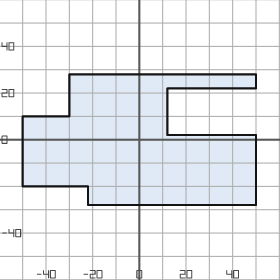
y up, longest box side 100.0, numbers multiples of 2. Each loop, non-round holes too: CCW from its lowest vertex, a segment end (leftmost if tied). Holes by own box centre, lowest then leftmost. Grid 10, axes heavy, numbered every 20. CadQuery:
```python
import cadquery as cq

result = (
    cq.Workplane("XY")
    .moveTo(-22.0, -28.0)
    .lineTo(50.0, -28.0)
    .lineTo(50.0, 2.0)
    .lineTo(12.0, 2.0)
    .lineTo(12.0, 22.0)
    .lineTo(50.0, 22.0)
    .lineTo(50.0, 28.0)
    .lineTo(-30.0, 28.0)
    .lineTo(-30.0, 10.0)
    .lineTo(-50.0, 10.0)
    .lineTo(-50.0, -20.0)
    .lineTo(-22.0, -20.0)
    .close()
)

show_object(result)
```